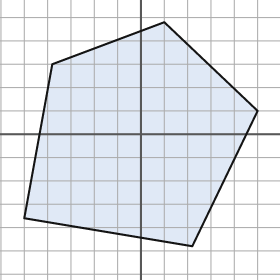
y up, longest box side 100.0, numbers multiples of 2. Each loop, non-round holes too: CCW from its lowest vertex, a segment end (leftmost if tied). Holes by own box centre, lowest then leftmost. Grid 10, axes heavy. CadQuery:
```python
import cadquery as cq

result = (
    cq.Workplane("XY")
    .moveTo(22.0, -48.0)
    .lineTo(50.0, 10.0)
    .lineTo(10.0, 48.0)
    .lineTo(-38.0, 30.0)
    .lineTo(-50.0, -36.0)
    .close()
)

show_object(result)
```